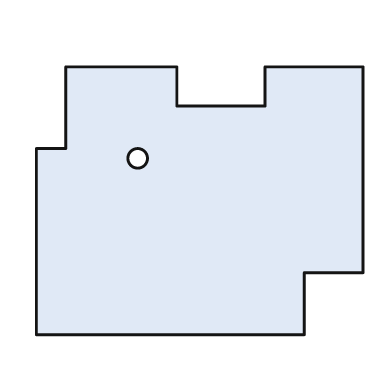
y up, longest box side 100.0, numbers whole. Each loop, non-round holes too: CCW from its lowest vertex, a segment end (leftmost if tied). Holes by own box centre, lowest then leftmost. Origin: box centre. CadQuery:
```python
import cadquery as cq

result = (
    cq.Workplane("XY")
    .moveTo(-50.0, -41.0)
    .lineTo(32.0, -41.0)
    .lineTo(32.0, -22.0)
    .lineTo(50.0, -22.0)
    .lineTo(50.0, 41.0)
    .lineTo(20.0, 41.0)
    .lineTo(20.0, 29.0)
    .lineTo(-7.0, 29.0)
    .lineTo(-7.0, 41.0)
    .lineTo(-41.0, 41.0)
    .lineTo(-41.0, 16.0)
    .lineTo(-50.0, 16.0)
    .close()
    .moveTo(-19.0, 13.0)
    .circle(3.0)
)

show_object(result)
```